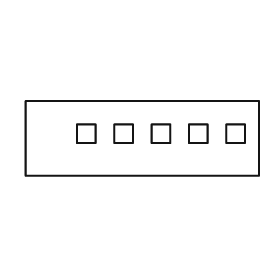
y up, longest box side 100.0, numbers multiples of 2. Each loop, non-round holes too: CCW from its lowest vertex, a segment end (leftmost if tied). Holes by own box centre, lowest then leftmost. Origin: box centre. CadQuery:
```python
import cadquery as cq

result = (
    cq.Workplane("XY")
    .moveTo(-50.0, -16.0)
    .lineTo(50.0, -16.0)
    .lineTo(50.0, 16.0)
    .lineTo(-50.0, 16.0)
    .close()
    .moveTo(-28.0, -2.0)
    .lineTo(-20.0, -2.0)
    .lineTo(-20.0, 6.0)
    .lineTo(-28.0, 6.0)
    .close()
    .moveTo(-12.0, -2.0)
    .lineTo(-4.0, -2.0)
    .lineTo(-4.0, 6.0)
    .lineTo(-12.0, 6.0)
    .close()
    .moveTo(4.0, -2.0)
    .lineTo(12.0, -2.0)
    .lineTo(12.0, 6.0)
    .lineTo(4.0, 6.0)
    .close()
    .moveTo(20.0, -2.0)
    .lineTo(28.0, -2.0)
    .lineTo(28.0, 6.0)
    .lineTo(20.0, 6.0)
    .close()
    .moveTo(36.0, -2.0)
    .lineTo(44.0, -2.0)
    .lineTo(44.0, 6.0)
    .lineTo(36.0, 6.0)
    .close()
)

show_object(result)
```